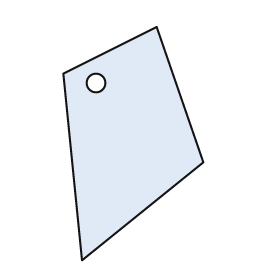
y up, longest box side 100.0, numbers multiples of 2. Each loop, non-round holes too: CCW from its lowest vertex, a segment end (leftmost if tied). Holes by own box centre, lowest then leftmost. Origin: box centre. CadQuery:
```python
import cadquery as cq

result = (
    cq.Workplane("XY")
    .moveTo(-22.0, -50.0)
    .lineTo(30.0, -8.0)
    .lineTo(10.0, 50.0)
    .lineTo(-30.0, 30.0)
    .close()
    .moveTo(-16.0, 26.0)
    .circle(4.0)
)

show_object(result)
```